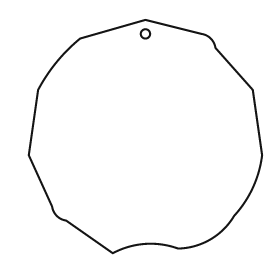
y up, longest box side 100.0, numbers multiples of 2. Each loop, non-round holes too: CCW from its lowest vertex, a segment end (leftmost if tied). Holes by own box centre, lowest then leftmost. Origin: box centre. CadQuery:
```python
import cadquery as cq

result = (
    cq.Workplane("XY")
    .moveTo(-14.0, -50.0)
    .threePointArc((0.0, -46.0), (14.0, -48.0))
    .threePointArc((28.0, -44.0), (38.0, -34.0))
    .threePointArc((46.0, -22.0), (50.0, -8.0))
    .lineTo(46.0, 20.0)
    .lineTo(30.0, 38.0)
    .threePointArc((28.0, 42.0), (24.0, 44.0))
    .lineTo(0.0, 50.0)
    .lineTo(-28.0, 42.0)
    .threePointArc((-38.0, 32.0), (-46.0, 20.0))
    .lineTo(-50.0, -8.0)
    .lineTo(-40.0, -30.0)
    .threePointArc((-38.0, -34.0), (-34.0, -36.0))
    .close()
    .moveTo(0.0, 44.0)
    .circle(2.0)
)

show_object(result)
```